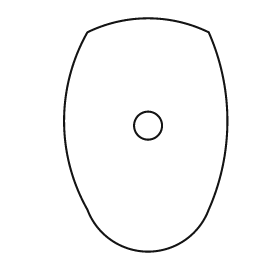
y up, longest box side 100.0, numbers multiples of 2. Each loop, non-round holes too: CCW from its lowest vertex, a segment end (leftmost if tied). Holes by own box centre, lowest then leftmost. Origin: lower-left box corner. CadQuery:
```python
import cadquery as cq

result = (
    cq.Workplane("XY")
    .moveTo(10.0, 18.0)
    .threePointArc((36.0, 0.0), (62.0, 18.0))
    .threePointArc((70.0, 56.0), (62.0, 94.0))
    .threePointArc((36.0, 100.0), (10.0, 94.0))
    .threePointArc((0.0, 56.0), (10.0, 18.0))
    .close()
    .moveTo(36.0, 54.0)
    .circle(6.0)
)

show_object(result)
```